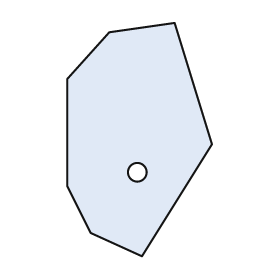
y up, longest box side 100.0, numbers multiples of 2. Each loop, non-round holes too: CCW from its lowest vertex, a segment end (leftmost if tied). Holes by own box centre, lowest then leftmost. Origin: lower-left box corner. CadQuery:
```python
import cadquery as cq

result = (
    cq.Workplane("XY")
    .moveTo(32.0, 0.0)
    .lineTo(62.0, 48.0)
    .lineTo(46.0, 100.0)
    .lineTo(18.0, 96.0)
    .lineTo(0.0, 76.0)
    .lineTo(0.0, 30.0)
    .lineTo(10.0, 10.0)
    .close()
    .moveTo(30.0, 36.0)
    .circle(4.0)
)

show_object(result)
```